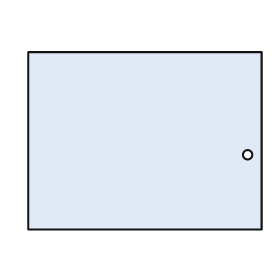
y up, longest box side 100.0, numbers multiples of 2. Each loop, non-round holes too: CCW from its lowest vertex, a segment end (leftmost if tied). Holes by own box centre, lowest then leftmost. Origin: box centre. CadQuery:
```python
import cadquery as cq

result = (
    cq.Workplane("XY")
    .moveTo(-50.0, -38.0)
    .lineTo(50.0, -38.0)
    .lineTo(50.0, 38.0)
    .lineTo(-50.0, 38.0)
    .close()
    .moveTo(44.0, -6.0)
    .circle(2.0)
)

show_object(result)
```